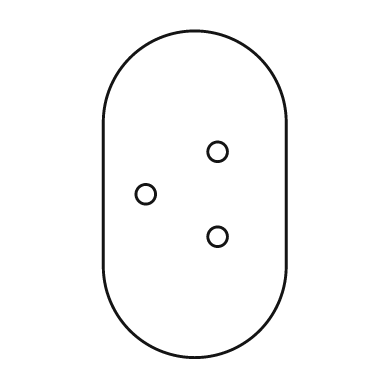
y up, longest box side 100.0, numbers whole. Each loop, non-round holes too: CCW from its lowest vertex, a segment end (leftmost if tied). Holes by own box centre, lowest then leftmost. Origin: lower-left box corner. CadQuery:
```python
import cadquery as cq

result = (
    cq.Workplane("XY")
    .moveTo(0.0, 28.0)
    .threePointArc((28.0, 0.0), (56.0, 28.0))
    .lineTo(56.0, 72.0)
    .threePointArc((28.0, 100.0), (0.0, 72.0))
    .close()
    .moveTo(35.0, 37.0)
    .circle(3.0)
    .moveTo(13.0, 50.0)
    .circle(3.0)
    .moveTo(35.0, 63.0)
    .circle(3.0)
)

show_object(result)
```